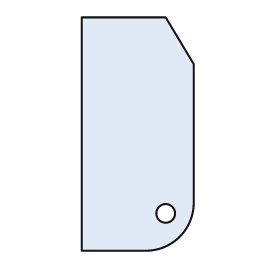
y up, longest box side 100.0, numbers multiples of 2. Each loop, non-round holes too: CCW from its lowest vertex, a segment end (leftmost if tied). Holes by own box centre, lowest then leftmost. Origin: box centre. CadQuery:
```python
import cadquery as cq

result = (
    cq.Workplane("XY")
    .moveTo(-24.0, -50.0)
    .lineTo(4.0, -50.0)
    .threePointArc((18.0, -44.0), (24.0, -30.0))
    .lineTo(24.0, 30.0)
    .lineTo(12.0, 50.0)
    .lineTo(-24.0, 50.0)
    .close()
    .moveTo(12.0, -34.0)
    .circle(4.0)
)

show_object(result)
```